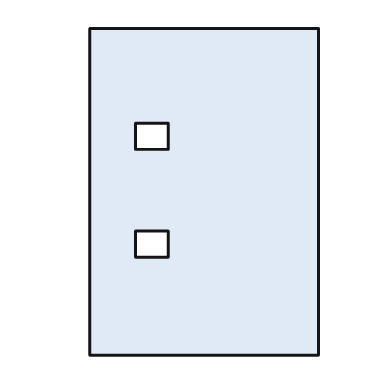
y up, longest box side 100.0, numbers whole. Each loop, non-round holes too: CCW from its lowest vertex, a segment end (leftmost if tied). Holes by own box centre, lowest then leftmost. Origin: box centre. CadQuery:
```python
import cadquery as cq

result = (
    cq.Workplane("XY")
    .moveTo(-35.0, -50.0)
    .lineTo(35.0, -50.0)
    .lineTo(35.0, 50.0)
    .lineTo(-35.0, 50.0)
    .close()
    .moveTo(-21.0, -20.0)
    .lineTo(-11.0, -20.0)
    .lineTo(-11.0, -12.0)
    .lineTo(-21.0, -12.0)
    .close()
    .moveTo(-21.0, 13.0)
    .lineTo(-11.0, 13.0)
    .lineTo(-11.0, 21.0)
    .lineTo(-21.0, 21.0)
    .close()
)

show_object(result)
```